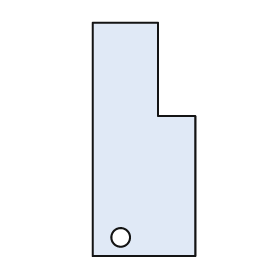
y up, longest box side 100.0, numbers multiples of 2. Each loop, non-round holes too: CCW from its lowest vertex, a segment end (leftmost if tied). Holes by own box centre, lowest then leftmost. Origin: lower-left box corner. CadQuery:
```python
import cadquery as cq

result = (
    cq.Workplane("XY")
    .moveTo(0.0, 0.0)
    .lineTo(44.0, 0.0)
    .lineTo(44.0, 60.0)
    .lineTo(28.0, 60.0)
    .lineTo(28.0, 100.0)
    .lineTo(0.0, 100.0)
    .close()
    .moveTo(12.0, 8.0)
    .circle(4.0)
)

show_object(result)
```